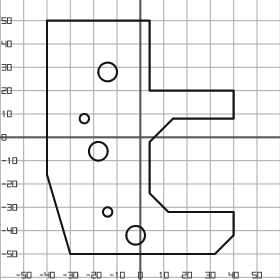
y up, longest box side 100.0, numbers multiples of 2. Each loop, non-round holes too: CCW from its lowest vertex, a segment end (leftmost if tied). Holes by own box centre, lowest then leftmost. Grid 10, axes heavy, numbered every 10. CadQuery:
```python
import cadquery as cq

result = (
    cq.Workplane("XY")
    .moveTo(-30.0, -50.0)
    .lineTo(32.0, -50.0)
    .lineTo(40.0, -42.0)
    .lineTo(40.0, -32.0)
    .lineTo(12.0, -32.0)
    .lineTo(4.0, -24.0)
    .lineTo(4.0, -2.0)
    .lineTo(14.0, 8.0)
    .lineTo(40.0, 8.0)
    .lineTo(40.0, 20.0)
    .lineTo(4.0, 20.0)
    .lineTo(4.0, 50.0)
    .lineTo(-40.0, 50.0)
    .lineTo(-40.0, -16.0)
    .close()
    .moveTo(-2.0, -42.0)
    .circle(4.0)
    .moveTo(-14.0, -32.0)
    .circle(2.0)
    .moveTo(-18.0, -6.0)
    .circle(4.0)
    .moveTo(-24.0, 8.0)
    .circle(2.0)
    .moveTo(-14.0, 28.0)
    .circle(4.0)
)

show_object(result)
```